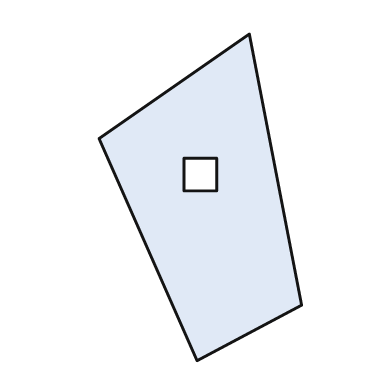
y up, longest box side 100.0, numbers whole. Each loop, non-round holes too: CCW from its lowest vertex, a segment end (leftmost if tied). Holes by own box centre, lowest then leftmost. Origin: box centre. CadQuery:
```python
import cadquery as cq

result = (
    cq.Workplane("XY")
    .moveTo(-1.0, -50.0)
    .lineTo(31.0, -33.0)
    .lineTo(15.0, 50.0)
    .lineTo(-31.0, 18.0)
    .close()
    .moveTo(-5.0, 2.0)
    .lineTo(5.0, 2.0)
    .lineTo(5.0, 12.0)
    .lineTo(-5.0, 12.0)
    .close()
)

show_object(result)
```